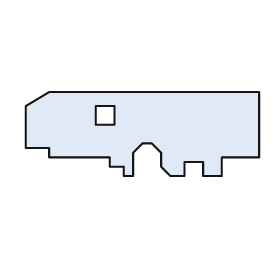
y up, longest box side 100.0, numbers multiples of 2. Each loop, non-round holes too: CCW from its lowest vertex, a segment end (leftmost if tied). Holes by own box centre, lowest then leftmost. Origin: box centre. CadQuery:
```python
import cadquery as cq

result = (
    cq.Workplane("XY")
    .moveTo(-8.0, -18.0)
    .lineTo(-4.0, -18.0)
    .lineTo(-4.0, -8.0)
    .lineTo(0.0, -4.0)
    .lineTo(4.0, -4.0)
    .lineTo(8.0, -8.0)
    .lineTo(8.0, -14.0)
    .lineTo(12.0, -18.0)
    .lineTo(18.0, -18.0)
    .lineTo(18.0, -12.0)
    .lineTo(26.0, -12.0)
    .lineTo(26.0, -18.0)
    .lineTo(34.0, -18.0)
    .lineTo(34.0, -10.0)
    .lineTo(50.0, -10.0)
    .lineTo(50.0, 18.0)
    .lineTo(-40.0, 18.0)
    .lineTo(-50.0, 12.0)
    .lineTo(-50.0, -6.0)
    .lineTo(-40.0, -6.0)
    .lineTo(-40.0, -10.0)
    .lineTo(-14.0, -10.0)
    .lineTo(-14.0, -14.0)
    .lineTo(-8.0, -14.0)
    .close()
    .moveTo(-20.0, 4.0)
    .lineTo(-12.0, 4.0)
    .lineTo(-12.0, 12.0)
    .lineTo(-20.0, 12.0)
    .close()
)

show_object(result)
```